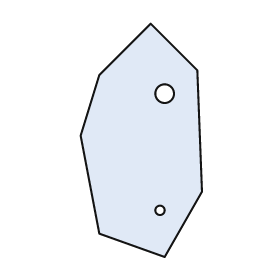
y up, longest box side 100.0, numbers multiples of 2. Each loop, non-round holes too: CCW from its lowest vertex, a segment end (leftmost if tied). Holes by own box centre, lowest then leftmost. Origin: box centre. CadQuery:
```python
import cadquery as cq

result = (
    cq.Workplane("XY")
    .moveTo(10.0, -50.0)
    .lineTo(26.0, -22.0)
    .lineTo(24.0, 30.0)
    .lineTo(4.0, 50.0)
    .lineTo(-18.0, 28.0)
    .lineTo(-26.0, 2.0)
    .lineTo(-18.0, -40.0)
    .close()
    .moveTo(8.0, -30.0)
    .circle(2.0)
    .moveTo(10.0, 20.0)
    .circle(4.0)
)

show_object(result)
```